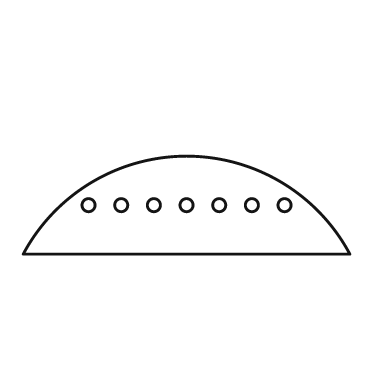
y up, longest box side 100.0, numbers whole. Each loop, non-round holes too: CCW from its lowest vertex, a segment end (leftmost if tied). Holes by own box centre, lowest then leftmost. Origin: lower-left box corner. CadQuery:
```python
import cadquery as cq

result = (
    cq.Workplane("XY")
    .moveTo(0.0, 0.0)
    .lineTo(100.0, 0.0)
    .threePointArc((50.0, 30.0), (0.0, 0.0))
    .close()
    .moveTo(20.0, 15.0)
    .circle(2.0)
    .moveTo(30.0, 15.0)
    .circle(2.0)
    .moveTo(40.0, 15.0)
    .circle(2.0)
    .moveTo(50.0, 15.0)
    .circle(2.0)
    .moveTo(60.0, 15.0)
    .circle(2.0)
    .moveTo(70.0, 15.0)
    .circle(2.0)
    .moveTo(80.0, 15.0)
    .circle(2.0)
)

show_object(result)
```